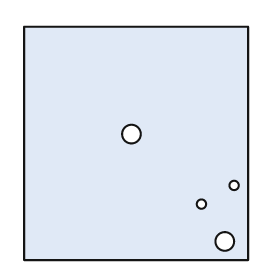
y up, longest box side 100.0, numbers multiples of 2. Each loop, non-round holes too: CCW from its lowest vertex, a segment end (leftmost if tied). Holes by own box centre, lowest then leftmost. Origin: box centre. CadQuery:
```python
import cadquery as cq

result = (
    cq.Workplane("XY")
    .moveTo(-48.0, -50.0)
    .lineTo(48.0, -50.0)
    .lineTo(48.0, 50.0)
    .lineTo(-48.0, 50.0)
    .close()
    .moveTo(38.0, -42.0)
    .circle(4.0)
    .moveTo(28.0, -26.0)
    .circle(2.0)
    .moveTo(42.0, -18.0)
    .circle(2.0)
    .moveTo(-2.0, 4.0)
    .circle(4.0)
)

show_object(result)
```